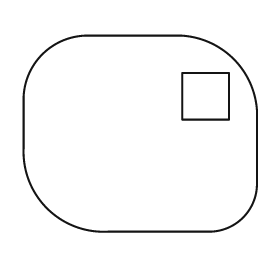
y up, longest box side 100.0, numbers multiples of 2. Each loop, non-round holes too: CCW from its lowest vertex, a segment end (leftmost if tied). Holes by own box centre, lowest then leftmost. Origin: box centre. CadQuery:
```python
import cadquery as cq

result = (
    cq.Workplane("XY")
    .moveTo(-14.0, -42.0)
    .lineTo(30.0, -42.0)
    .threePointArc((44.0, -36.0), (50.0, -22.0))
    .lineTo(50.0, 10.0)
    .threePointArc((40.0, 32.0), (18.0, 42.0))
    .lineTo(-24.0, 42.0)
    .threePointArc((-42.0, 34.0), (-50.0, 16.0))
    .lineTo(-50.0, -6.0)
    .threePointArc((-40.0, -32.0), (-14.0, -42.0))
    .close()
    .moveTo(18.0, 6.0)
    .lineTo(38.0, 6.0)
    .lineTo(38.0, 26.0)
    .lineTo(18.0, 26.0)
    .close()
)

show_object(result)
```